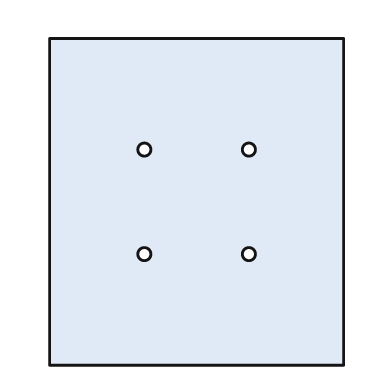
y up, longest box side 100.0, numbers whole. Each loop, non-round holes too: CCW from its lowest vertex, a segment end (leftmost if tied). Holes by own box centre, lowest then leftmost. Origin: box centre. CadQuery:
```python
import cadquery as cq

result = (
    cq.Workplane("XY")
    .moveTo(-45.0, -50.0)
    .lineTo(45.0, -50.0)
    .lineTo(45.0, 50.0)
    .lineTo(-45.0, 50.0)
    .close()
    .moveTo(-16.0, -16.0)
    .circle(2.0)
    .moveTo(16.0, -16.0)
    .circle(2.0)
    .moveTo(-16.0, 16.0)
    .circle(2.0)
    .moveTo(16.0, 16.0)
    .circle(2.0)
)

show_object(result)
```